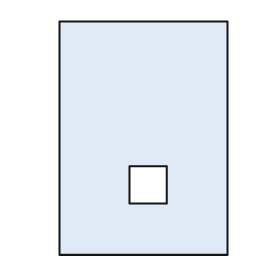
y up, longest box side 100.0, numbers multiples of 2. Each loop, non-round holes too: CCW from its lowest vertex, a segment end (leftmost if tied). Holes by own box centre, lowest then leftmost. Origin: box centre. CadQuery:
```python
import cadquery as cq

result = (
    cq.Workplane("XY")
    .moveTo(-36.0, -50.0)
    .lineTo(36.0, -50.0)
    .lineTo(36.0, 50.0)
    .lineTo(-36.0, 50.0)
    .close()
    .moveTo(-6.0, -28.0)
    .lineTo(10.0, -28.0)
    .lineTo(10.0, -12.0)
    .lineTo(-6.0, -12.0)
    .close()
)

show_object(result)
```